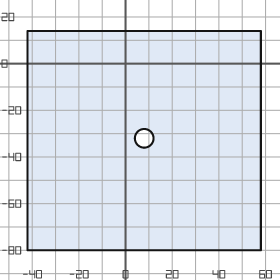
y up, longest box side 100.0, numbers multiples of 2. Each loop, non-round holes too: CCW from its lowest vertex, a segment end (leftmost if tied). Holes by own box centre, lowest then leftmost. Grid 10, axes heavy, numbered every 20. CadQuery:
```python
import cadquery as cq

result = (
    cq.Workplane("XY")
    .moveTo(-42.0, -80.0)
    .lineTo(58.0, -80.0)
    .lineTo(58.0, 14.0)
    .lineTo(-42.0, 14.0)
    .close()
    .moveTo(8.0, -32.0)
    .circle(4.0)
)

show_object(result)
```